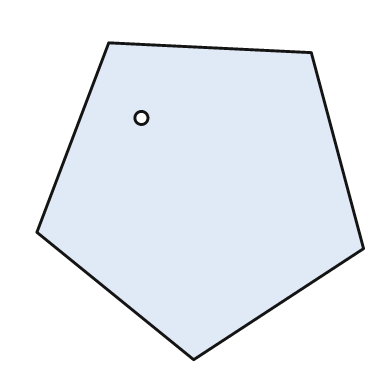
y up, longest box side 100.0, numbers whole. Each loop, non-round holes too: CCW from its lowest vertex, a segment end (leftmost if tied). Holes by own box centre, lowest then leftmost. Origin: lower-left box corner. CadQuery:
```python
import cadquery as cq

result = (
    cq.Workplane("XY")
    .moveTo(48.0, 0.0)
    .lineTo(100.0, 34.0)
    .lineTo(84.0, 94.0)
    .lineTo(22.0, 97.0)
    .lineTo(0.0, 39.0)
    .close()
    .moveTo(32.0, 74.0)
    .circle(2.0)
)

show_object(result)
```